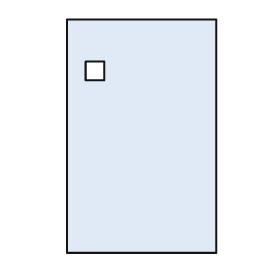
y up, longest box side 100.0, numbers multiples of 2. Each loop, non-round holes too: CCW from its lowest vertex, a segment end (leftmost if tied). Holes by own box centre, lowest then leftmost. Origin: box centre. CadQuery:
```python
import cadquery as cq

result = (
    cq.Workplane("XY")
    .moveTo(-32.0, -50.0)
    .lineTo(32.0, -50.0)
    .lineTo(32.0, 50.0)
    .lineTo(-32.0, 50.0)
    .close()
    .moveTo(-24.0, 24.0)
    .lineTo(-16.0, 24.0)
    .lineTo(-16.0, 32.0)
    .lineTo(-24.0, 32.0)
    .close()
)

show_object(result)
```